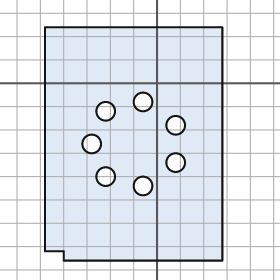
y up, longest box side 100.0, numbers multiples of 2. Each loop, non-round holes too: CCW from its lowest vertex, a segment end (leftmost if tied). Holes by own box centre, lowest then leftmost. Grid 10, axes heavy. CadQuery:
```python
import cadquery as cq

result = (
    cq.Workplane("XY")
    .moveTo(-40.0, -76.0)
    .lineTo(28.0, -76.0)
    .lineTo(28.0, 24.0)
    .lineTo(-48.0, 24.0)
    .lineTo(-48.0, -72.0)
    .lineTo(-40.0, -72.0)
    .close()
    .moveTo(-6.0, -44.0)
    .circle(4.0)
    .moveTo(-22.0, -40.0)
    .circle(4.0)
    .moveTo(8.0, -34.0)
    .circle(4.0)
    .moveTo(-28.0, -26.0)
    .circle(4.0)
    .moveTo(8.0, -18.0)
    .circle(4.0)
    .moveTo(-22.0, -12.0)
    .circle(4.0)
    .moveTo(-6.0, -8.0)
    .circle(4.0)
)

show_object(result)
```